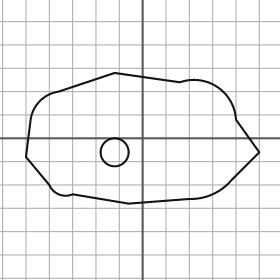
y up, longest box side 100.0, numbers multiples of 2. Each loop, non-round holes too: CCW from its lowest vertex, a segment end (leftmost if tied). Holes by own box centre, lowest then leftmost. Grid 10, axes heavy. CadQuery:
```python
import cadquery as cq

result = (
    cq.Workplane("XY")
    .moveTo(-6.0, -28.0)
    .lineTo(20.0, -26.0)
    .threePointArc((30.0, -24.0), (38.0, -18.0))
    .lineTo(50.0, -6.0)
    .lineTo(40.0, 8.0)
    .threePointArc((32.0, 22.0), (16.0, 24.0))
    .lineTo(-12.0, 28.0)
    .lineTo(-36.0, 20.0)
    .threePointArc((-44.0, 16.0), (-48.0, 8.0))
    .lineTo(-50.0, -8.0)
    .lineTo(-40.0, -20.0)
    .threePointArc((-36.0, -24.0), (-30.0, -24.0))
    .close()
    .moveTo(-12.0, -6.0)
    .circle(6.0)
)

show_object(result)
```